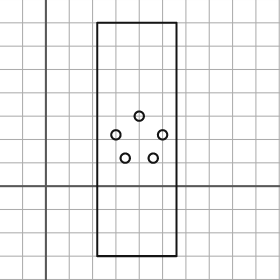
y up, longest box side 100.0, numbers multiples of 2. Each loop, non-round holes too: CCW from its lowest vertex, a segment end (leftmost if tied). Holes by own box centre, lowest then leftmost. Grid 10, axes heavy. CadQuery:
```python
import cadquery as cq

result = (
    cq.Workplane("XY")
    .moveTo(22.0, -30.0)
    .lineTo(56.0, -30.0)
    .lineTo(56.0, 70.0)
    .lineTo(22.0, 70.0)
    .close()
    .moveTo(34.0, 12.0)
    .circle(2.0)
    .moveTo(46.0, 12.0)
    .circle(2.0)
    .moveTo(30.0, 22.0)
    .circle(2.0)
    .moveTo(50.0, 22.0)
    .circle(2.0)
    .moveTo(40.0, 30.0)
    .circle(2.0)
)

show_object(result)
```